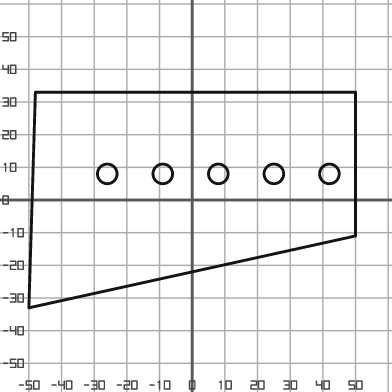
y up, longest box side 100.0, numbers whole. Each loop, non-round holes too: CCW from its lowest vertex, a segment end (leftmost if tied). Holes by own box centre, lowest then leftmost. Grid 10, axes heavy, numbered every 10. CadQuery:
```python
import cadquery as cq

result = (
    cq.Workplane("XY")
    .moveTo(-50.0, -33.0)
    .lineTo(50.0, -11.0)
    .lineTo(50.0, 33.0)
    .lineTo(-48.0, 33.0)
    .close()
    .moveTo(-26.0, 8.0)
    .circle(3.0)
    .moveTo(-9.0, 8.0)
    .circle(3.0)
    .moveTo(8.0, 8.0)
    .circle(3.0)
    .moveTo(25.0, 8.0)
    .circle(3.0)
    .moveTo(42.0, 8.0)
    .circle(3.0)
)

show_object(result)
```